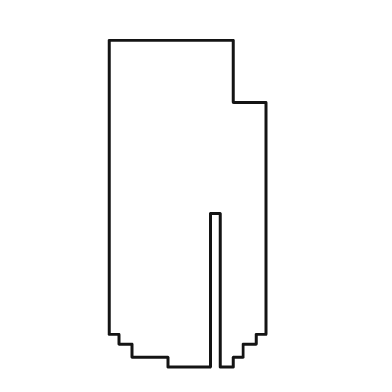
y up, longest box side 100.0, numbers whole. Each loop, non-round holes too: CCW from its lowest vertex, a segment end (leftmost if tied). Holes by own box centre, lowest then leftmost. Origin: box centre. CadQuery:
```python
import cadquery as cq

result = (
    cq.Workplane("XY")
    .moveTo(-6.0, -50.0)
    .lineTo(7.0, -50.0)
    .lineTo(7.0, -3.0)
    .lineTo(10.0, -3.0)
    .lineTo(10.0, -50.0)
    .lineTo(14.0, -50.0)
    .lineTo(14.0, -47.0)
    .lineTo(17.0, -47.0)
    .lineTo(17.0, -43.0)
    .lineTo(21.0, -43.0)
    .lineTo(21.0, -40.0)
    .lineTo(24.0, -40.0)
    .lineTo(24.0, 31.0)
    .lineTo(14.0, 31.0)
    .lineTo(14.0, 50.0)
    .lineTo(-24.0, 50.0)
    .lineTo(-24.0, -40.0)
    .lineTo(-21.0, -40.0)
    .lineTo(-21.0, -43.0)
    .lineTo(-17.0, -43.0)
    .lineTo(-17.0, -47.0)
    .lineTo(-6.0, -47.0)
    .close()
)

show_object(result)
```